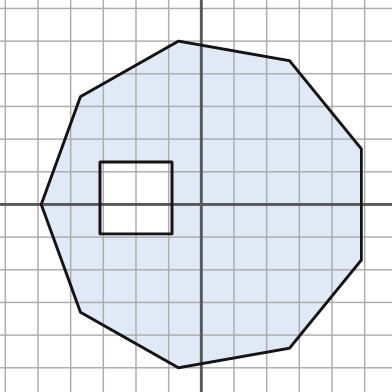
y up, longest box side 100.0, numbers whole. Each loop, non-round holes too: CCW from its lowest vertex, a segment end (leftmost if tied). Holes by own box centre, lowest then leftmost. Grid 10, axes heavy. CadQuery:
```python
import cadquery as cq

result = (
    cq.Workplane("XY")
    .moveTo(-7.0, -50.0)
    .lineTo(27.0, -44.0)
    .lineTo(49.0, -17.0)
    .lineTo(49.0, 17.0)
    .lineTo(27.0, 44.0)
    .lineTo(-7.0, 50.0)
    .lineTo(-37.0, 33.0)
    .lineTo(-49.0, 0.0)
    .lineTo(-37.0, -33.0)
    .close()
    .moveTo(-31.0, -9.0)
    .lineTo(-9.0, -9.0)
    .lineTo(-9.0, 13.0)
    .lineTo(-31.0, 13.0)
    .close()
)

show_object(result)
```